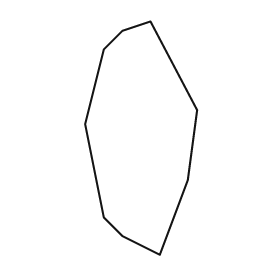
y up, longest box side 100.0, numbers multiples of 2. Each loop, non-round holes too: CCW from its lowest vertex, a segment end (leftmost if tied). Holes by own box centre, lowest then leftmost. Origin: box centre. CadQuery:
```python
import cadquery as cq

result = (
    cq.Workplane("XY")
    .moveTo(8.0, -50.0)
    .lineTo(20.0, -18.0)
    .lineTo(24.0, 12.0)
    .lineTo(4.0, 50.0)
    .lineTo(-8.0, 46.0)
    .lineTo(-16.0, 38.0)
    .lineTo(-24.0, 6.0)
    .lineTo(-16.0, -34.0)
    .lineTo(-8.0, -42.0)
    .close()
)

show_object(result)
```